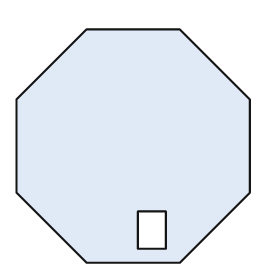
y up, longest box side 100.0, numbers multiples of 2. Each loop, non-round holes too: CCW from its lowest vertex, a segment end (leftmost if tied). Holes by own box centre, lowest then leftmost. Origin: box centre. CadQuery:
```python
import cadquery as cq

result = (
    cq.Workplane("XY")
    .moveTo(-20.0, -50.0)
    .lineTo(20.0, -50.0)
    .lineTo(50.0, -20.0)
    .lineTo(50.0, 20.0)
    .lineTo(20.0, 50.0)
    .lineTo(-20.0, 50.0)
    .lineTo(-50.0, 20.0)
    .lineTo(-50.0, -20.0)
    .close()
    .moveTo(2.0, -44.0)
    .lineTo(14.0, -44.0)
    .lineTo(14.0, -28.0)
    .lineTo(2.0, -28.0)
    .close()
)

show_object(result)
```